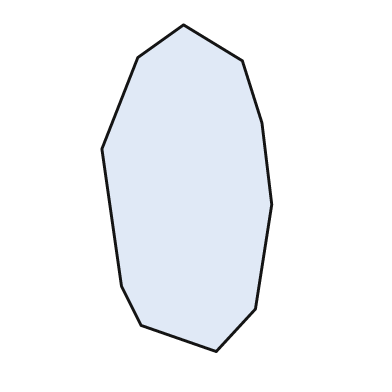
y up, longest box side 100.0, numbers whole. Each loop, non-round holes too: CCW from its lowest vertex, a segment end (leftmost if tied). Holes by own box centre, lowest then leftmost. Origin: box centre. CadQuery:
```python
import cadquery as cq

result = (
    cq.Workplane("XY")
    .moveTo(9.0, -50.0)
    .lineTo(21.0, -37.0)
    .lineTo(26.0, -5.0)
    .lineTo(23.0, 20.0)
    .lineTo(17.0, 39.0)
    .lineTo(-1.0, 50.0)
    .lineTo(-15.0, 40.0)
    .lineTo(-26.0, 12.0)
    .lineTo(-20.0, -30.0)
    .lineTo(-14.0, -42.0)
    .close()
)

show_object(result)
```